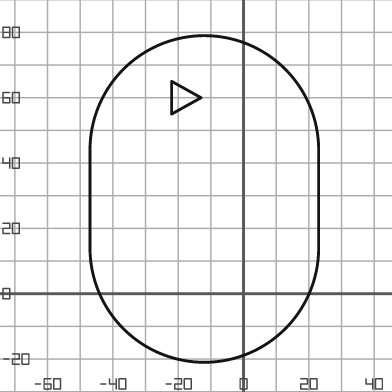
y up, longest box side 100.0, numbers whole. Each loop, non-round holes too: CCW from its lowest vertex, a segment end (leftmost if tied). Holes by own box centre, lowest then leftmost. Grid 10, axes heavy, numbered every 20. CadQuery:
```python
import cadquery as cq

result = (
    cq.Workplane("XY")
    .moveTo(-47.0, 14.0)
    .threePointArc((-12.0, -21.0), (23.0, 14.0))
    .lineTo(23.0, 44.0)
    .threePointArc((-12.0, 79.0), (-47.0, 44.0))
    .close()
    .moveTo(-22.0, 55.0)
    .lineTo(-13.0, 60.0)
    .lineTo(-22.0, 65.0)
    .close()
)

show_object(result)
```